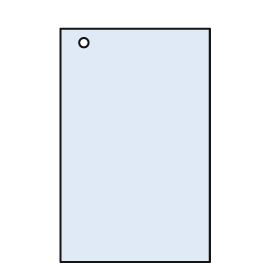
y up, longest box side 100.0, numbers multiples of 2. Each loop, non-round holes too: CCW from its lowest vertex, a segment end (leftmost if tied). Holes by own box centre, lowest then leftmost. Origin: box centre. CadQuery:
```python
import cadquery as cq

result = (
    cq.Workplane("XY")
    .moveTo(-32.0, -50.0)
    .lineTo(32.0, -50.0)
    .lineTo(32.0, 50.0)
    .lineTo(-32.0, 50.0)
    .close()
    .moveTo(-22.0, 44.0)
    .circle(2.0)
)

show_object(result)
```